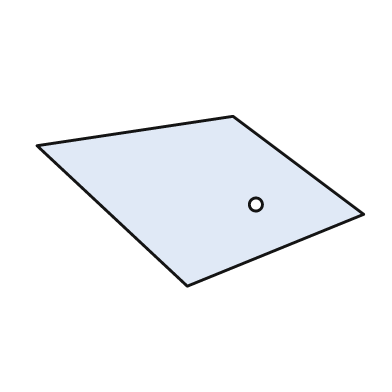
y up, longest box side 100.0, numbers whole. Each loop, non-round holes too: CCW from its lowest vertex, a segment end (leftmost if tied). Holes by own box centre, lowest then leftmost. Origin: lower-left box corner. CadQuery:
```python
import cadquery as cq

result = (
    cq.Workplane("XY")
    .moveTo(46.0, 0.0)
    .lineTo(100.0, 22.0)
    .lineTo(60.0, 52.0)
    .lineTo(0.0, 43.0)
    .close()
    .moveTo(67.0, 25.0)
    .circle(2.0)
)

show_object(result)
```